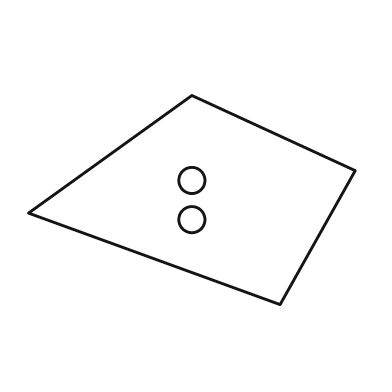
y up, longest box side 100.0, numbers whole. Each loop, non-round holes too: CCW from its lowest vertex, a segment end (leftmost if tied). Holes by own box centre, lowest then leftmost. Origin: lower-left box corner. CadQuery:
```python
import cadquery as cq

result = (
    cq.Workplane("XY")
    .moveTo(77.0, 0.0)
    .lineTo(100.0, 41.0)
    .lineTo(50.0, 64.0)
    .lineTo(0.0, 28.0)
    .close()
    .moveTo(50.0, 26.0)
    .circle(4.0)
    .moveTo(50.0, 38.0)
    .circle(4.0)
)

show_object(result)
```